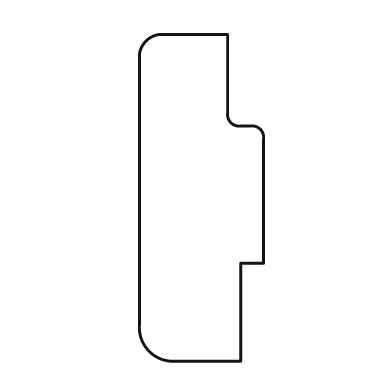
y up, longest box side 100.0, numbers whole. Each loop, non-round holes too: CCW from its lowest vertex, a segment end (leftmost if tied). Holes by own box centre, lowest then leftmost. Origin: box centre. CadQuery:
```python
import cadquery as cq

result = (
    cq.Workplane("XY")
    .moveTo(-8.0, -50.0)
    .lineTo(12.0, -50.0)
    .lineTo(12.0, -20.0)
    .lineTo(19.0, -20.0)
    .lineTo(19.0, 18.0)
    .threePointArc((18.0, 21.0), (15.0, 22.0))
    .lineTo(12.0, 22.0)
    .threePointArc((9.0, 23.0), (8.0, 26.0))
    .lineTo(8.0, 50.0)
    .lineTo(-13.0, 50.0)
    .threePointArc((-17.0, 48.0), (-19.0, 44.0))
    .lineTo(-19.0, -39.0)
    .threePointArc((-16.0, -47.0), (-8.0, -50.0))
    .close()
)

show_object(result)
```